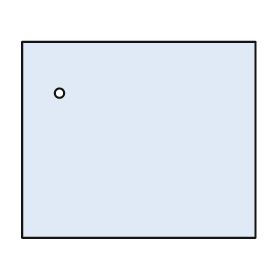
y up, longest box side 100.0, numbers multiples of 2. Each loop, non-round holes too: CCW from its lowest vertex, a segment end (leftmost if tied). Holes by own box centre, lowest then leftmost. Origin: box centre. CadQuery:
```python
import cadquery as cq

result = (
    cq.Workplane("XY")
    .moveTo(-50.0, -42.0)
    .lineTo(50.0, -42.0)
    .lineTo(50.0, 42.0)
    .lineTo(-50.0, 42.0)
    .close()
    .moveTo(-34.0, 20.0)
    .circle(2.0)
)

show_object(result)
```